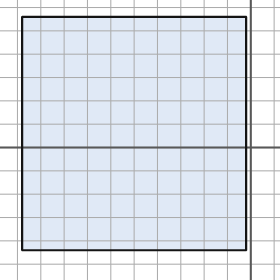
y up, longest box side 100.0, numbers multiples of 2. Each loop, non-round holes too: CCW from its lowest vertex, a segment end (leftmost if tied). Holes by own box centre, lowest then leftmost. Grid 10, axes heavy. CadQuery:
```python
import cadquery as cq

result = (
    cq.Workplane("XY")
    .moveTo(-98.0, -44.0)
    .lineTo(-2.0, -44.0)
    .lineTo(-2.0, 56.0)
    .lineTo(-98.0, 56.0)
    .close()
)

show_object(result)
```